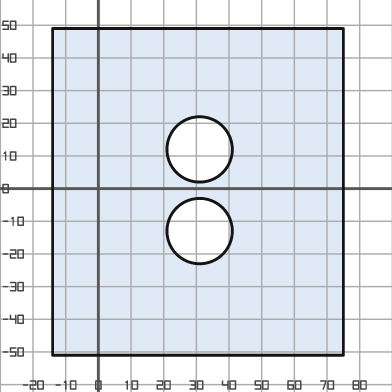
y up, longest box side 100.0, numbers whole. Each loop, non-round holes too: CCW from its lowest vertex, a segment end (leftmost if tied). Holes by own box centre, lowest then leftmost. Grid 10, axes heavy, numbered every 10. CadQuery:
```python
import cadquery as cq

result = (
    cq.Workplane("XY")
    .moveTo(-14.0, -51.0)
    .lineTo(75.0, -51.0)
    .lineTo(75.0, 49.0)
    .lineTo(-14.0, 49.0)
    .close()
    .moveTo(31.0, -13.0)
    .circle(10.0)
    .moveTo(31.0, 12.0)
    .circle(10.0)
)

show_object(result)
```